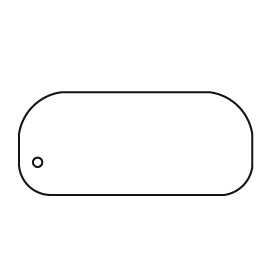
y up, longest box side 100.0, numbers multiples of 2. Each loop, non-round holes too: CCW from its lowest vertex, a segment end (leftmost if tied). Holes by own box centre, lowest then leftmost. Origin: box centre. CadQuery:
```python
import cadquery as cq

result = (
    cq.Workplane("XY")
    .moveTo(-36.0, -22.0)
    .lineTo(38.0, -22.0)
    .threePointArc((46.0, -18.0), (50.0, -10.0))
    .lineTo(50.0, 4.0)
    .threePointArc((44.0, 16.0), (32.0, 22.0))
    .lineTo(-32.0, 22.0)
    .threePointArc((-44.0, 16.0), (-50.0, 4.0))
    .lineTo(-50.0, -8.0)
    .threePointArc((-46.0, -18.0), (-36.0, -22.0))
    .close()
    .moveTo(-42.0, -8.0)
    .circle(2.0)
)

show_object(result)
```